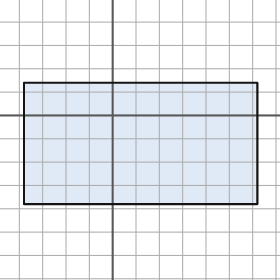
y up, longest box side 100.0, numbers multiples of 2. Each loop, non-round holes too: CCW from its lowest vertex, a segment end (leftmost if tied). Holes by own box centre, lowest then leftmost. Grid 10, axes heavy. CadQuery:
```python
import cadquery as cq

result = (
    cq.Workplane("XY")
    .moveTo(-38.0, -38.0)
    .lineTo(62.0, -38.0)
    .lineTo(62.0, 14.0)
    .lineTo(-38.0, 14.0)
    .close()
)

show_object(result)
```